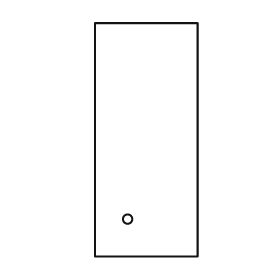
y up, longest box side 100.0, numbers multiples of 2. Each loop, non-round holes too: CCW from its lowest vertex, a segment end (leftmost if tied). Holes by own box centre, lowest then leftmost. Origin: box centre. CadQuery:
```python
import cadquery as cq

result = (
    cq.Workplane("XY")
    .moveTo(-22.0, -50.0)
    .lineTo(22.0, -50.0)
    .lineTo(22.0, 50.0)
    .lineTo(-22.0, 50.0)
    .close()
    .moveTo(-8.0, -34.0)
    .circle(2.0)
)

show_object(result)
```